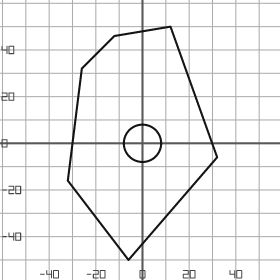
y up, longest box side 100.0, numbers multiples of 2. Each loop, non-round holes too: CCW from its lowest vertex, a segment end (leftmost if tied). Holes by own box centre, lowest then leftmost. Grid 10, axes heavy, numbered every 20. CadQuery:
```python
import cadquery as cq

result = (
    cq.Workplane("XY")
    .moveTo(-6.0, -50.0)
    .lineTo(32.0, -6.0)
    .lineTo(12.0, 50.0)
    .lineTo(-12.0, 46.0)
    .lineTo(-26.0, 32.0)
    .lineTo(-32.0, -16.0)
    .close()
    .moveTo(0.0, 0.0)
    .circle(8.0)
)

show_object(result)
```